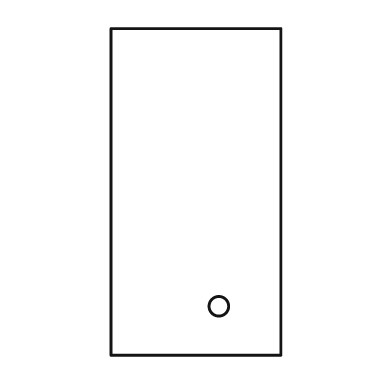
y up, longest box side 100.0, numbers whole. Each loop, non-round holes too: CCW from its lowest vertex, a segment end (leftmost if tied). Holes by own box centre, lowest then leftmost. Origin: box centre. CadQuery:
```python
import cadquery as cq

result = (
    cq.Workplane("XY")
    .moveTo(-26.0, -50.0)
    .lineTo(26.0, -50.0)
    .lineTo(26.0, 50.0)
    .lineTo(-26.0, 50.0)
    .close()
    .moveTo(7.0, -35.0)
    .circle(3.0)
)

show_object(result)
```